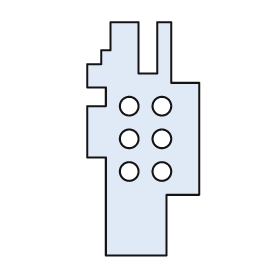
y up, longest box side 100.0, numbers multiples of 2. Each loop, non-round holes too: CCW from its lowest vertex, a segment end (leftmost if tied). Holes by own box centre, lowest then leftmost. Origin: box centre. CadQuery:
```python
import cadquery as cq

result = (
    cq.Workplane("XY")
    .moveTo(-16.0, -50.0)
    .lineTo(10.0, -50.0)
    .lineTo(10.0, -24.0)
    .lineTo(24.0, -24.0)
    .lineTo(24.0, 24.0)
    .lineTo(12.0, 24.0)
    .lineTo(12.0, 50.0)
    .lineTo(6.0, 50.0)
    .lineTo(6.0, 28.0)
    .lineTo(-2.0, 28.0)
    .lineTo(-2.0, 50.0)
    .lineTo(-14.0, 50.0)
    .lineTo(-14.0, 38.0)
    .lineTo(-18.0, 38.0)
    .lineTo(-18.0, 32.0)
    .lineTo(-24.0, 32.0)
    .lineTo(-24.0, 22.0)
    .lineTo(-16.0, 22.0)
    .lineTo(-16.0, 14.0)
    .lineTo(-24.0, 14.0)
    .lineTo(-24.0, -8.0)
    .lineTo(-16.0, -8.0)
    .close()
    .moveTo(-6.0, -14.0)
    .circle(4.0)
    .moveTo(8.0, -14.0)
    .circle(4.0)
    .moveTo(-6.0, 0.0)
    .circle(4.0)
    .moveTo(8.0, 0.0)
    .circle(4.0)
    .moveTo(-6.0, 14.0)
    .circle(4.0)
    .moveTo(8.0, 14.0)
    .circle(4.0)
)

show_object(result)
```